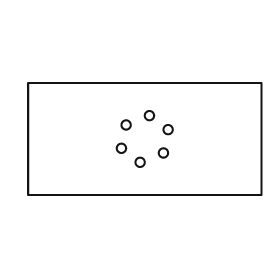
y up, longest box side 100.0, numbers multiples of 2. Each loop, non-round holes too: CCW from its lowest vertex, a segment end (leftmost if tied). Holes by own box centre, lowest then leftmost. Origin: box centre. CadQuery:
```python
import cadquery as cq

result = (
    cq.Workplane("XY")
    .moveTo(-50.0, -24.0)
    .lineTo(50.0, -24.0)
    .lineTo(50.0, 24.0)
    .lineTo(-50.0, 24.0)
    .close()
    .moveTo(-2.0, -10.0)
    .circle(2.0)
    .moveTo(8.0, -6.0)
    .circle(2.0)
    .moveTo(-10.0, -4.0)
    .circle(2.0)
    .moveTo(10.0, 4.0)
    .circle(2.0)
    .moveTo(-8.0, 6.0)
    .circle(2.0)
    .moveTo(2.0, 10.0)
    .circle(2.0)
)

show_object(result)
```